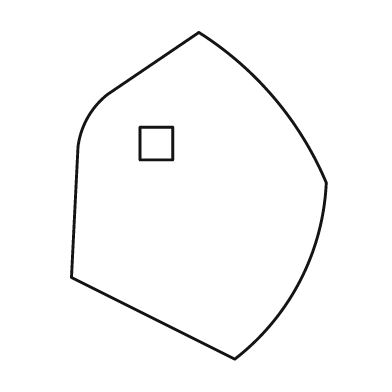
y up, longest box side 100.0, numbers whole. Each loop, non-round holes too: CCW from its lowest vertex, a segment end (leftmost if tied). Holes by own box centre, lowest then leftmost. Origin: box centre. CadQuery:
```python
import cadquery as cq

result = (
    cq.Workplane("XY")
    .moveTo(11.0, -50.0)
    .threePointArc((31.0, -26.0), (39.0, 4.0))
    .threePointArc((23.0, 30.0), (0.0, 50.0))
    .lineTo(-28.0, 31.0)
    .threePointArc((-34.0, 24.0), (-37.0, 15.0))
    .lineTo(-39.0, -25.0)
    .close()
    .moveTo(-18.0, 11.0)
    .lineTo(-8.0, 11.0)
    .lineTo(-8.0, 21.0)
    .lineTo(-18.0, 21.0)
    .close()
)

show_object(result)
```